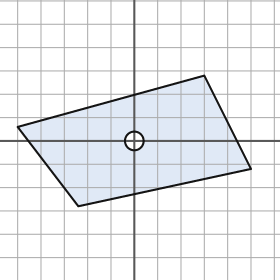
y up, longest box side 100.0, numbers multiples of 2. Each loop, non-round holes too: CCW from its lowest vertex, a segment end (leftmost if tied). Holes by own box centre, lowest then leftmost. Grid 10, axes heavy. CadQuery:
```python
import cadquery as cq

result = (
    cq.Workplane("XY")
    .moveTo(-24.0, -28.0)
    .lineTo(50.0, -12.0)
    .lineTo(30.0, 28.0)
    .lineTo(-50.0, 6.0)
    .close()
    .moveTo(0.0, 0.0)
    .circle(4.0)
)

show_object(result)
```